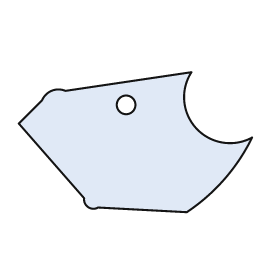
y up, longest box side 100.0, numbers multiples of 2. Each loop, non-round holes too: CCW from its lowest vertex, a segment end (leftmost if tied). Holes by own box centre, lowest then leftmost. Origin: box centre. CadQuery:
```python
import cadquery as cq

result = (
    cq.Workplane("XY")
    .moveTo(22.0, -30.0)
    .threePointArc((38.0, -16.0), (50.0, 2.0))
    .threePointArc((26.0, 6.0), (24.0, 30.0))
    .lineTo(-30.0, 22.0)
    .threePointArc((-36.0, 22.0), (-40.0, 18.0))
    .lineTo(-50.0, 8.0)
    .lineTo(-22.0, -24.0)
    .threePointArc((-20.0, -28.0), (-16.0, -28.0))
    .close()
    .moveTo(-4.0, 16.0)
    .circle(4.0)
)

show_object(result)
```